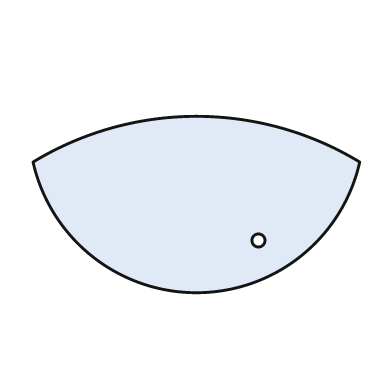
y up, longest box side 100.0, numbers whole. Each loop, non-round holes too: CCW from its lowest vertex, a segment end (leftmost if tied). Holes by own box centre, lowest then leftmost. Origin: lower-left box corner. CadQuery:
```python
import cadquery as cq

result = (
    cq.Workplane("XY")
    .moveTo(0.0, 40.0)
    .threePointArc((50.0, 0.0), (100.0, 40.0))
    .threePointArc((50.0, 54.0), (0.0, 40.0))
    .close()
    .moveTo(69.0, 16.0)
    .circle(2.0)
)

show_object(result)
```